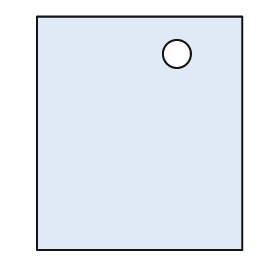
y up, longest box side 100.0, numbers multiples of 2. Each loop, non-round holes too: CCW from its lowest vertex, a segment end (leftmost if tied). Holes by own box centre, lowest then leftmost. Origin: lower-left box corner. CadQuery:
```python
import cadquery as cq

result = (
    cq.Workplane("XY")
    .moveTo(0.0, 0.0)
    .lineTo(88.0, 0.0)
    .lineTo(88.0, 100.0)
    .lineTo(0.0, 100.0)
    .close()
    .moveTo(60.0, 84.0)
    .circle(6.0)
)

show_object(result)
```